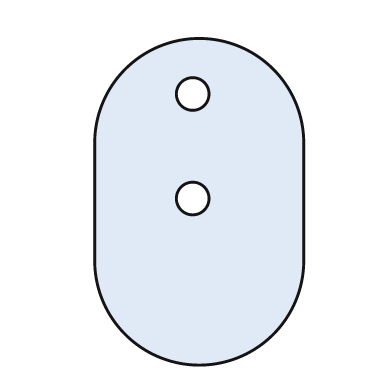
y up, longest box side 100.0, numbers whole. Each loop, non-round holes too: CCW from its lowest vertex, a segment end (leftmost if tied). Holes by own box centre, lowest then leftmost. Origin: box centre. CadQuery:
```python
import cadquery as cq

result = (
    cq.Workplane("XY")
    .moveTo(-32.0, -18.0)
    .threePointArc((0.0, -50.0), (32.0, -18.0))
    .lineTo(32.0, 18.0)
    .threePointArc((0.0, 50.0), (-32.0, 18.0))
    .close()
    .moveTo(-2.0, 1.0)
    .circle(5.0)
    .moveTo(-2.0, 33.0)
    .circle(5.0)
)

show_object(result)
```